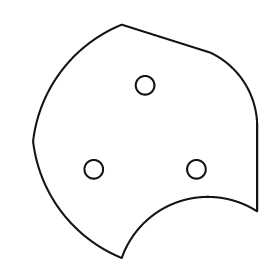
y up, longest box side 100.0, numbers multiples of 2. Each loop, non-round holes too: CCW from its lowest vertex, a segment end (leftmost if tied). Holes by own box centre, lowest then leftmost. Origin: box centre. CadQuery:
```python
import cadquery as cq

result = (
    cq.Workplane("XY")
    .moveTo(-10.0, -50.0)
    .threePointArc((14.0, -26.0), (48.0, -30.0))
    .lineTo(48.0, 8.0)
    .threePointArc((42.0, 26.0), (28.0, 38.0))
    .lineTo(-10.0, 50.0)
    .threePointArc((-36.0, 30.0), (-48.0, 0.0))
    .threePointArc((-36.0, -30.0), (-10.0, -50.0))
    .close()
    .moveTo(-22.0, -12.0)
    .circle(4.0)
    .moveTo(22.0, -12.0)
    .circle(4.0)
    .moveTo(0.0, 24.0)
    .circle(4.0)
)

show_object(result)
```